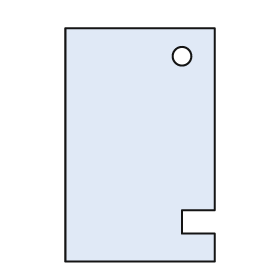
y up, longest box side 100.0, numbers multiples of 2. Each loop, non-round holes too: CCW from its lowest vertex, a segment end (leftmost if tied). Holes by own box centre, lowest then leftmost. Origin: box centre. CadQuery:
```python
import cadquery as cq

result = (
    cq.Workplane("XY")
    .moveTo(-32.0, -50.0)
    .lineTo(32.0, -50.0)
    .lineTo(32.0, -38.0)
    .lineTo(18.0, -38.0)
    .lineTo(18.0, -28.0)
    .lineTo(32.0, -28.0)
    .lineTo(32.0, 50.0)
    .lineTo(-32.0, 50.0)
    .close()
    .moveTo(18.0, 38.0)
    .circle(4.0)
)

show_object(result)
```